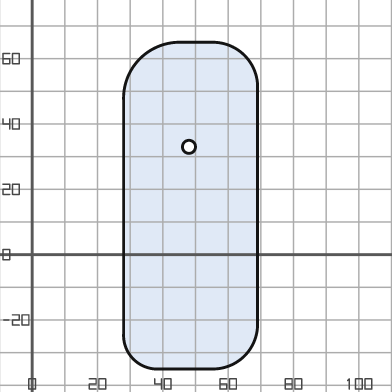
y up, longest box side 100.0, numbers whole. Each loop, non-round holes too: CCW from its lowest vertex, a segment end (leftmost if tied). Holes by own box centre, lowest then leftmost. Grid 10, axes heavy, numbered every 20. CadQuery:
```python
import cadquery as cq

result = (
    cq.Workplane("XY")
    .moveTo(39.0, -35.0)
    .lineTo(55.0, -35.0)
    .threePointArc((65.0, -31.0), (69.0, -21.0))
    .lineTo(69.0, 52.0)
    .threePointArc((65.0, 61.0), (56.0, 65.0))
    .lineTo(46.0, 65.0)
    .threePointArc((33.0, 60.0), (28.0, 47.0))
    .lineTo(28.0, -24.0)
    .threePointArc((31.0, -32.0), (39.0, -35.0))
    .close()
    .moveTo(48.0, 33.0)
    .circle(2.0)
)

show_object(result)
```